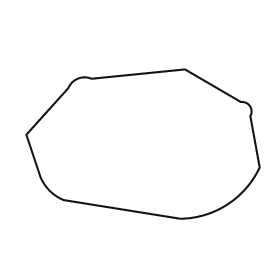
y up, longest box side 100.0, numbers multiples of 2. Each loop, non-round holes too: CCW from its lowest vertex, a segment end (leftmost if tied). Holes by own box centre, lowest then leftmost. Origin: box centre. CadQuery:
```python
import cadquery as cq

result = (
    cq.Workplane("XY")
    .moveTo(16.0, -32.0)
    .threePointArc((36.0, -26.0), (50.0, -10.0))
    .lineTo(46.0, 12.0)
    .threePointArc((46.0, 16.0), (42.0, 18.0))
    .lineTo(18.0, 32.0)
    .lineTo(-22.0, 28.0)
    .threePointArc((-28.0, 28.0), (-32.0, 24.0))
    .lineTo(-50.0, 4.0)
    .lineTo(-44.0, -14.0)
    .threePointArc((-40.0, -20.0), (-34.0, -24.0))
    .close()
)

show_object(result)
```